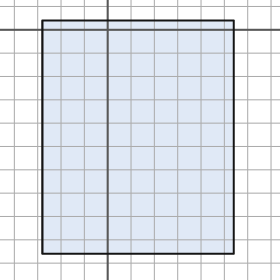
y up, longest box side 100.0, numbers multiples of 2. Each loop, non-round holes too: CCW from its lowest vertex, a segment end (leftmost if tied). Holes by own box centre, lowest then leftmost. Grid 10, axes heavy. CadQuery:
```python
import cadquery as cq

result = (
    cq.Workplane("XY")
    .moveTo(-28.0, -96.0)
    .lineTo(54.0, -96.0)
    .lineTo(54.0, 4.0)
    .lineTo(-28.0, 4.0)
    .close()
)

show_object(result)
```